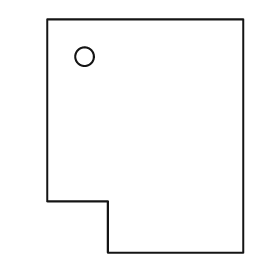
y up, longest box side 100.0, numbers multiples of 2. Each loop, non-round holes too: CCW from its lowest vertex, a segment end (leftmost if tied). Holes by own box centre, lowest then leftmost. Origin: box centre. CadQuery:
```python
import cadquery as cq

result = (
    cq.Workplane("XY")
    .moveTo(-16.0, -50.0)
    .lineTo(42.0, -50.0)
    .lineTo(42.0, 50.0)
    .lineTo(-42.0, 50.0)
    .lineTo(-42.0, -28.0)
    .lineTo(-16.0, -28.0)
    .close()
    .moveTo(-26.0, 34.0)
    .circle(4.0)
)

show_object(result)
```